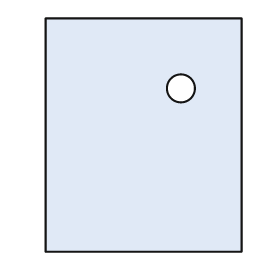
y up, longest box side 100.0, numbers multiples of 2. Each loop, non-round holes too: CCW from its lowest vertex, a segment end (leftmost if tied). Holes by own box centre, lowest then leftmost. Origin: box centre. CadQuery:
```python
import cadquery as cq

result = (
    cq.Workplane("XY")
    .moveTo(-42.0, -50.0)
    .lineTo(42.0, -50.0)
    .lineTo(42.0, 50.0)
    .lineTo(-42.0, 50.0)
    .close()
    .moveTo(16.0, 20.0)
    .circle(6.0)
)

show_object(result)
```